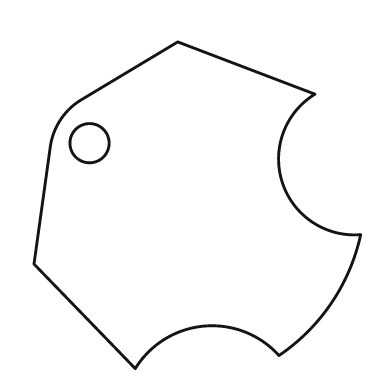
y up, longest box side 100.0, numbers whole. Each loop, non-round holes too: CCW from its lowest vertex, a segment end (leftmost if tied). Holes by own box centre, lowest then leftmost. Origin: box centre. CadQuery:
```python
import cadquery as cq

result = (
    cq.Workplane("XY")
    .moveTo(-19.0, -50.0)
    .threePointArc((2.0, -37.0), (25.0, -46.0))
    .threePointArc((41.0, -30.0), (50.0, -9.0))
    .threePointArc((26.0, 7.0), (36.0, 34.0))
    .lineTo(-6.0, 50.0)
    .lineTo(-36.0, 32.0)
    .threePointArc((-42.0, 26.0), (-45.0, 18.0))
    .lineTo(-50.0, -18.0)
    .close()
    .moveTo(-33.0, 19.0)
    .circle(6.0)
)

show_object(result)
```